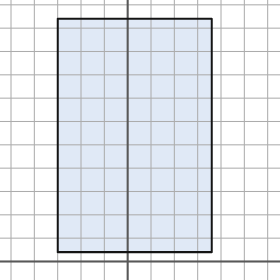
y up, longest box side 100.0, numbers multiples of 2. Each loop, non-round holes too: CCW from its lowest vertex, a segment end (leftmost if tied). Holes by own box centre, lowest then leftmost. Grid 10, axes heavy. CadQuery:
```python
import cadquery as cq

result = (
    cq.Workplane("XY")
    .moveTo(-30.0, 4.0)
    .lineTo(36.0, 4.0)
    .lineTo(36.0, 104.0)
    .lineTo(-30.0, 104.0)
    .close()
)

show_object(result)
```